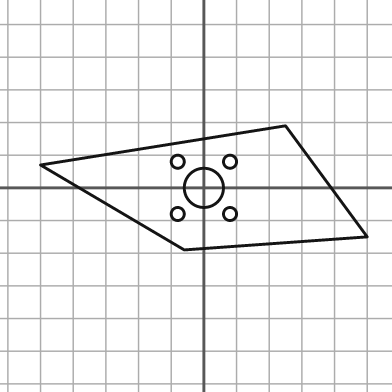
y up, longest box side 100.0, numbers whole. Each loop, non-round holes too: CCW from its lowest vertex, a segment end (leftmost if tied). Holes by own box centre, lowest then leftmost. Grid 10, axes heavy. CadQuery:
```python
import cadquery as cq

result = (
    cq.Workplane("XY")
    .moveTo(-6.0, -19.0)
    .lineTo(50.0, -15.0)
    .lineTo(25.0, 19.0)
    .lineTo(-50.0, 7.0)
    .close()
    .moveTo(-8.0, -8.0)
    .circle(2.0)
    .moveTo(8.0, -8.0)
    .circle(2.0)
    .moveTo(0.0, 0.0)
    .circle(6.0)
    .moveTo(-8.0, 8.0)
    .circle(2.0)
    .moveTo(8.0, 8.0)
    .circle(2.0)
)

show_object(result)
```